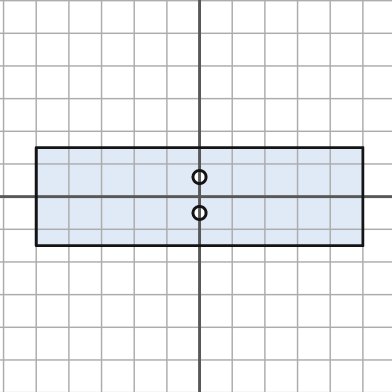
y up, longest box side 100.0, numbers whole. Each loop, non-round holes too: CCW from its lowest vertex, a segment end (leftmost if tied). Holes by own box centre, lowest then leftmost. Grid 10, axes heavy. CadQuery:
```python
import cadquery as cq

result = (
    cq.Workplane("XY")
    .moveTo(-50.0, -15.0)
    .lineTo(50.0, -15.0)
    .lineTo(50.0, 15.0)
    .lineTo(-50.0, 15.0)
    .close()
    .moveTo(0.0, -5.0)
    .circle(2.0)
    .moveTo(0.0, 6.0)
    .circle(2.0)
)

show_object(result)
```